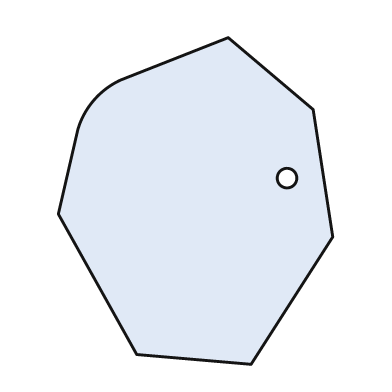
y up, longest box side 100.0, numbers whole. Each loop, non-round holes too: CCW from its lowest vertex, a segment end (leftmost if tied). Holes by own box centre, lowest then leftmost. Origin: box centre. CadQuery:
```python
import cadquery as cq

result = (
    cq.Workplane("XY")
    .moveTo(17.0, -50.0)
    .lineTo(42.0, -11.0)
    .lineTo(36.0, 28.0)
    .lineTo(10.0, 50.0)
    .lineTo(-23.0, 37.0)
    .threePointArc((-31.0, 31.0), (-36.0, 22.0))
    .lineTo(-42.0, -4.0)
    .lineTo(-18.0, -47.0)
    .close()
    .moveTo(28.0, 7.0)
    .circle(3.0)
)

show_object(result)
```